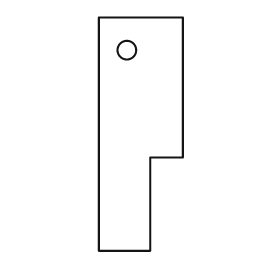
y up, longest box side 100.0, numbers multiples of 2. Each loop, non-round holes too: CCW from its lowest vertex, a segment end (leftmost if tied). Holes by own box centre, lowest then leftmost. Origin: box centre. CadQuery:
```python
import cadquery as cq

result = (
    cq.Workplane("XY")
    .moveTo(-18.0, -50.0)
    .lineTo(4.0, -50.0)
    .lineTo(4.0, -10.0)
    .lineTo(18.0, -10.0)
    .lineTo(18.0, 50.0)
    .lineTo(-18.0, 50.0)
    .close()
    .moveTo(-6.0, 36.0)
    .circle(4.0)
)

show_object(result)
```